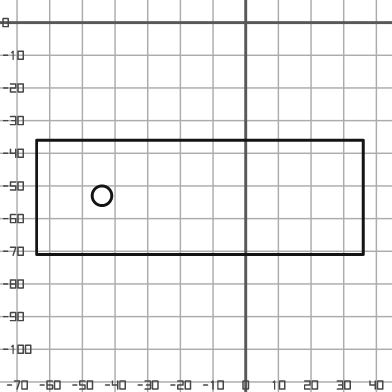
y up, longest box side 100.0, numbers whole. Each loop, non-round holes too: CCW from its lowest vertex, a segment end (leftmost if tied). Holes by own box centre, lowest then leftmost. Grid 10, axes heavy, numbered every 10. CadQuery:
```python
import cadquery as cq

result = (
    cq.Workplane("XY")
    .moveTo(-64.0, -71.0)
    .lineTo(36.0, -71.0)
    .lineTo(36.0, -36.0)
    .lineTo(-64.0, -36.0)
    .close()
    .moveTo(-44.0, -53.0)
    .circle(3.0)
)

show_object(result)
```